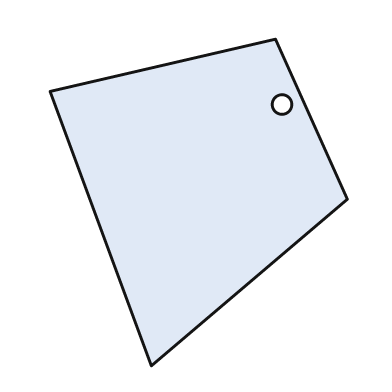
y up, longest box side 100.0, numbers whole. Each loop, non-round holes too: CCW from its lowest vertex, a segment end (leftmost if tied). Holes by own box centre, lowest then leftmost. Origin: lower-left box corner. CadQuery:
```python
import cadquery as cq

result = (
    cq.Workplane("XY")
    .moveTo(31.0, 0.0)
    .lineTo(91.0, 51.0)
    .lineTo(69.0, 100.0)
    .lineTo(0.0, 84.0)
    .close()
    .moveTo(71.0, 80.0)
    .circle(3.0)
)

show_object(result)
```